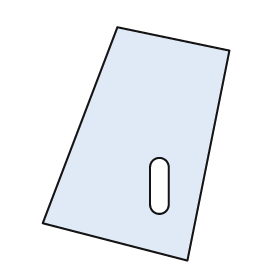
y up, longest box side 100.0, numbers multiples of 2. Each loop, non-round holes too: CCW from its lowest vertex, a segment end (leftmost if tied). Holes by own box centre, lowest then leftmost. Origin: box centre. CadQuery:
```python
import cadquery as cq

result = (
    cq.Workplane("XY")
    .moveTo(22.0, -50.0)
    .lineTo(40.0, 40.0)
    .lineTo(-8.0, 50.0)
    .lineTo(-40.0, -34.0)
    .close()
    .moveTo(6.0, -26.0)
    .threePointArc((10.0, -30.0), (14.0, -26.0))
    .lineTo(14.0, -10.0)
    .threePointArc((10.0, -6.0), (6.0, -10.0))
    .close()
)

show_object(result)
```